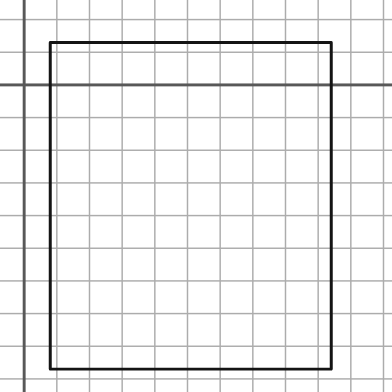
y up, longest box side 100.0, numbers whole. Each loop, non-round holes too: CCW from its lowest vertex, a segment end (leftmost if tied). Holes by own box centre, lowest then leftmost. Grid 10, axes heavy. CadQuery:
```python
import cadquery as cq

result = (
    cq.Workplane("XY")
    .moveTo(8.0, -87.0)
    .lineTo(94.0, -87.0)
    .lineTo(94.0, 13.0)
    .lineTo(8.0, 13.0)
    .close()
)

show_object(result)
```